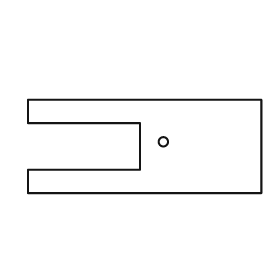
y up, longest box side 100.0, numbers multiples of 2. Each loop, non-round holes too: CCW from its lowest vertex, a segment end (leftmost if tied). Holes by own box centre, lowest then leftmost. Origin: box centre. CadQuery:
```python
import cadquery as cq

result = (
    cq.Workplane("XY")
    .moveTo(-50.0, -20.0)
    .lineTo(50.0, -20.0)
    .lineTo(50.0, 20.0)
    .lineTo(-50.0, 20.0)
    .lineTo(-50.0, 10.0)
    .lineTo(-2.0, 10.0)
    .lineTo(-2.0, -10.0)
    .lineTo(-50.0, -10.0)
    .close()
    .moveTo(8.0, 2.0)
    .circle(2.0)
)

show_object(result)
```